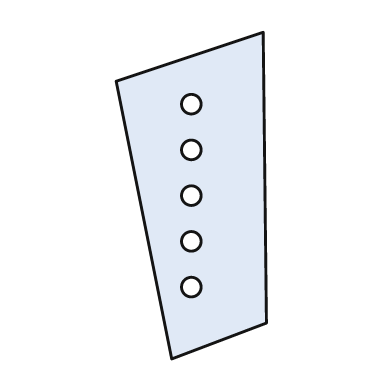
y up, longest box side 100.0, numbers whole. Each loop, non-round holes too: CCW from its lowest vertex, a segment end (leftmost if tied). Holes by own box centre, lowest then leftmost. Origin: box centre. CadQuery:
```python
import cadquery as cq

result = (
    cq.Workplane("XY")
    .moveTo(-6.0, -50.0)
    .lineTo(23.0, -39.0)
    .lineTo(22.0, 50.0)
    .lineTo(-23.0, 35.0)
    .close()
    .moveTo(0.0, -28.0)
    .circle(3.0)
    .moveTo(0.0, -14.0)
    .circle(3.0)
    .moveTo(0.0, 0.0)
    .circle(3.0)
    .moveTo(0.0, 14.0)
    .circle(3.0)
    .moveTo(0.0, 28.0)
    .circle(3.0)
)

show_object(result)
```